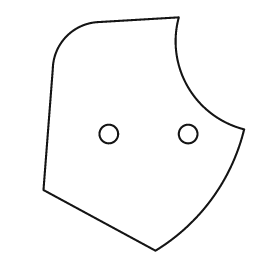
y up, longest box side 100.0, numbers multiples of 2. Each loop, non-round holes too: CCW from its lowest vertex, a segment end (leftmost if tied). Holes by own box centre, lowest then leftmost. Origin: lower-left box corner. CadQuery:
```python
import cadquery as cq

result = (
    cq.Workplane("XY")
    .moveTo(48.0, 0.0)
    .threePointArc((72.0, 22.0), (86.0, 52.0))
    .threePointArc((62.0, 70.0), (58.0, 100.0))
    .lineTo(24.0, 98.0)
    .threePointArc((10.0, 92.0), (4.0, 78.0))
    .lineTo(0.0, 26.0)
    .close()
    .moveTo(28.0, 50.0)
    .circle(4.0)
    .moveTo(62.0, 50.0)
    .circle(4.0)
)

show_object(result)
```